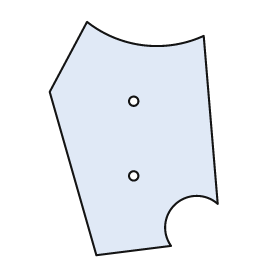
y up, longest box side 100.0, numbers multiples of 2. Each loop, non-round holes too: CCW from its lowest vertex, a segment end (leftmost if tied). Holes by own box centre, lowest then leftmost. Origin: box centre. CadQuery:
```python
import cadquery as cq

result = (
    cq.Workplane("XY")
    .moveTo(-16.0, -50.0)
    .lineTo(16.0, -46.0)
    .threePointArc((18.0, -28.0), (36.0, -28.0))
    .lineTo(30.0, 44.0)
    .threePointArc((4.0, 40.0), (-20.0, 50.0))
    .lineTo(-36.0, 20.0)
    .close()
    .moveTo(0.0, -16.0)
    .circle(2.0)
    .moveTo(0.0, 16.0)
    .circle(2.0)
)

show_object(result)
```